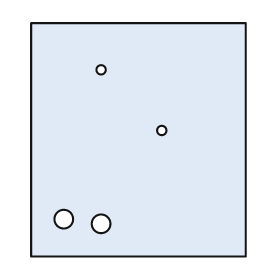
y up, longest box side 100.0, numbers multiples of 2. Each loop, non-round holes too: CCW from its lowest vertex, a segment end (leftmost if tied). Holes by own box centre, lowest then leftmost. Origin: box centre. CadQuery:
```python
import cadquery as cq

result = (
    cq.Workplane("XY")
    .moveTo(-46.0, -50.0)
    .lineTo(46.0, -50.0)
    .lineTo(46.0, 50.0)
    .lineTo(-46.0, 50.0)
    .close()
    .moveTo(-16.0, -36.0)
    .circle(4.0)
    .moveTo(-32.0, -34.0)
    .circle(4.0)
    .moveTo(10.0, 4.0)
    .circle(2.0)
    .moveTo(-16.0, 30.0)
    .circle(2.0)
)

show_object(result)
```